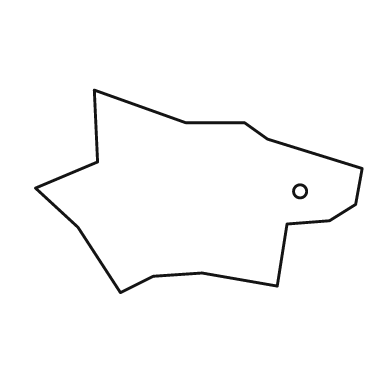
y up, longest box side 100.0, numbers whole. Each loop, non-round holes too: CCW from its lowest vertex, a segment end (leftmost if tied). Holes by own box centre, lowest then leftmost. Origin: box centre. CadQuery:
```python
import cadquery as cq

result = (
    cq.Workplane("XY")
    .moveTo(-24.0, -31.0)
    .lineTo(-14.0, -26.0)
    .lineTo(1.0, -25.0)
    .lineTo(24.0, -29.0)
    .lineTo(27.0, -10.0)
    .lineTo(40.0, -9.0)
    .lineTo(48.0, -4.0)
    .lineTo(50.0, 7.0)
    .lineTo(21.0, 16.0)
    .lineTo(14.0, 21.0)
    .lineTo(-4.0, 21.0)
    .lineTo(-32.0, 31.0)
    .lineTo(-31.0, 9.0)
    .lineTo(-50.0, 1.0)
    .lineTo(-37.0, -11.0)
    .close()
    .moveTo(31.0, 0.0)
    .circle(2.0)
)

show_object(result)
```